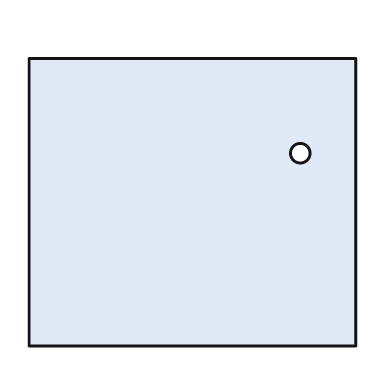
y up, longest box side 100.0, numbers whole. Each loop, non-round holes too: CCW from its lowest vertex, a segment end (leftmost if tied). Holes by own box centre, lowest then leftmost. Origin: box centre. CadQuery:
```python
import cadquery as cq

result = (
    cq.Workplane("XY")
    .moveTo(-50.0, -44.0)
    .lineTo(50.0, -44.0)
    .lineTo(50.0, 44.0)
    .lineTo(-50.0, 44.0)
    .close()
    .moveTo(33.0, 15.0)
    .circle(3.0)
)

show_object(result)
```